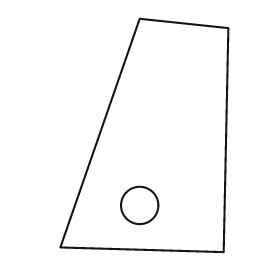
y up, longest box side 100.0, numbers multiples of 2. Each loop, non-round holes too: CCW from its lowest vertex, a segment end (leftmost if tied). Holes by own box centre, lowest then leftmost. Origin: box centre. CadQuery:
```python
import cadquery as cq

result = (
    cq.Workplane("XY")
    .moveTo(34.0, -50.0)
    .lineTo(36.0, 46.0)
    .lineTo(-2.0, 50.0)
    .lineTo(-36.0, -48.0)
    .close()
    .moveTo(-2.0, -30.0)
    .circle(8.0)
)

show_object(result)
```